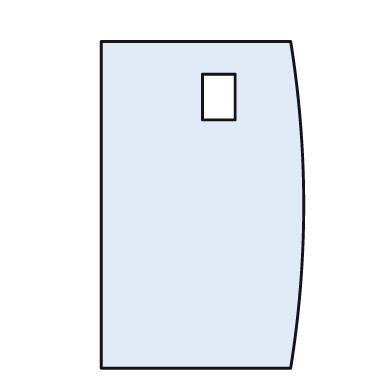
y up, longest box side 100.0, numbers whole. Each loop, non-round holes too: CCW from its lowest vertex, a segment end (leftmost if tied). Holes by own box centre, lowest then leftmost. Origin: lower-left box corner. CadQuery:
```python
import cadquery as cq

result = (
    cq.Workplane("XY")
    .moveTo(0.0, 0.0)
    .lineTo(58.0, 0.0)
    .threePointArc((62.0, 50.0), (58.0, 100.0))
    .lineTo(0.0, 100.0)
    .close()
    .moveTo(31.0, 76.0)
    .lineTo(41.0, 76.0)
    .lineTo(41.0, 90.0)
    .lineTo(31.0, 90.0)
    .close()
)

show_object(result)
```